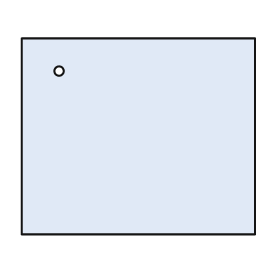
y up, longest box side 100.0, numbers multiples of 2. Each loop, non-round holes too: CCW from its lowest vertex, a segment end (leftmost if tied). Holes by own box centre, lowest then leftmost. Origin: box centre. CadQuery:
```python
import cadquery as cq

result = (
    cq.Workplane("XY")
    .moveTo(-50.0, -42.0)
    .lineTo(50.0, -42.0)
    .lineTo(50.0, 42.0)
    .lineTo(-50.0, 42.0)
    .close()
    .moveTo(-34.0, 28.0)
    .circle(2.0)
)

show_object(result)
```